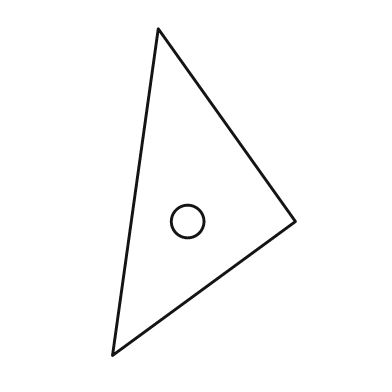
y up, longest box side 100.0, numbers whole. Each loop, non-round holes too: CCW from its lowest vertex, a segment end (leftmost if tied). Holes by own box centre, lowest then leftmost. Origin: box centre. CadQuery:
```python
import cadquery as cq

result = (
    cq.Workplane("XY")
    .moveTo(-28.0, -50.0)
    .lineTo(28.0, -9.0)
    .lineTo(-14.0, 50.0)
    .close()
    .moveTo(-5.0, -9.0)
    .circle(5.0)
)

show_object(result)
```